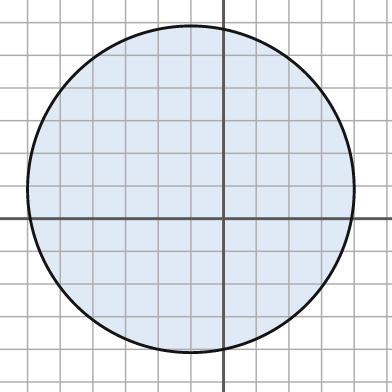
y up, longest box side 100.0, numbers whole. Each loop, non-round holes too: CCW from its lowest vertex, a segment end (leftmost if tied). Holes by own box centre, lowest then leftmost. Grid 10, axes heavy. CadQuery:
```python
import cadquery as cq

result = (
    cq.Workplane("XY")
    .moveTo(-10.0, 9.0)
    .circle(50.0)
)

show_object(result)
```